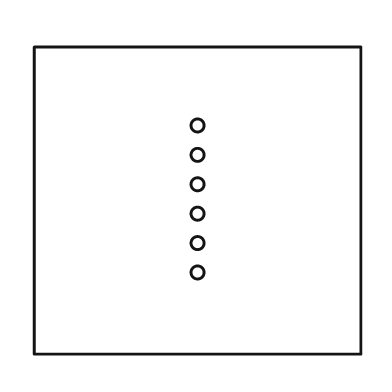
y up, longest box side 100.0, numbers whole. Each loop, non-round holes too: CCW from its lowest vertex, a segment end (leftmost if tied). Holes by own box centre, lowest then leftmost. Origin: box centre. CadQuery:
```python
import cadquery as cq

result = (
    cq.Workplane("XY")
    .moveTo(-50.0, -47.0)
    .lineTo(50.0, -47.0)
    .lineTo(50.0, 47.0)
    .lineTo(-50.0, 47.0)
    .close()
    .moveTo(0.0, -22.0)
    .circle(2.0)
    .moveTo(0.0, -13.0)
    .circle(2.0)
    .moveTo(0.0, -4.0)
    .circle(2.0)
    .moveTo(0.0, 5.0)
    .circle(2.0)
    .moveTo(0.0, 14.0)
    .circle(2.0)
    .moveTo(0.0, 23.0)
    .circle(2.0)
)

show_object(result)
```